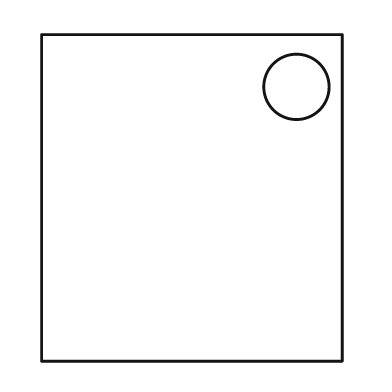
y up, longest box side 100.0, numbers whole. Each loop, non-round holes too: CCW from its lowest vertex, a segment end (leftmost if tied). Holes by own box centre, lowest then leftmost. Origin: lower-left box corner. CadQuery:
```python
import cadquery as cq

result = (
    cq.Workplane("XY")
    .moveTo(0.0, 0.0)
    .lineTo(92.0, 0.0)
    .lineTo(92.0, 100.0)
    .lineTo(0.0, 100.0)
    .close()
    .moveTo(78.0, 84.0)
    .circle(10.0)
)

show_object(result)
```